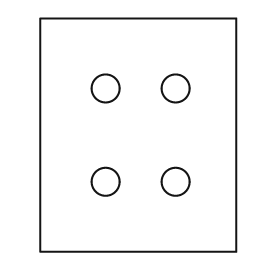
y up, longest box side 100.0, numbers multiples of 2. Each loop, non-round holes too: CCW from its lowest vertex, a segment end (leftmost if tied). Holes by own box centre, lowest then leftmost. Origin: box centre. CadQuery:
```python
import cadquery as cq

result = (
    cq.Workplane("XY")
    .moveTo(-42.0, -50.0)
    .lineTo(42.0, -50.0)
    .lineTo(42.0, 50.0)
    .lineTo(-42.0, 50.0)
    .close()
    .moveTo(-14.0, -20.0)
    .circle(6.0)
    .moveTo(16.0, -20.0)
    .circle(6.0)
    .moveTo(-14.0, 20.0)
    .circle(6.0)
    .moveTo(16.0, 20.0)
    .circle(6.0)
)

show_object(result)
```